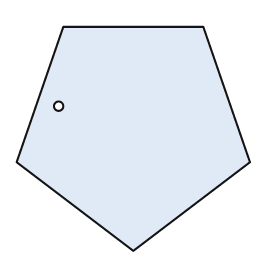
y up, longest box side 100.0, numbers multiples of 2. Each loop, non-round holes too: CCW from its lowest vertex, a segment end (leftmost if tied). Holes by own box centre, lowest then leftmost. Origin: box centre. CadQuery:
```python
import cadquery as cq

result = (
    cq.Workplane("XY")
    .moveTo(0.0, -48.0)
    .lineTo(50.0, -10.0)
    .lineTo(30.0, 48.0)
    .lineTo(-30.0, 48.0)
    .lineTo(-50.0, -10.0)
    .close()
    .moveTo(-32.0, 14.0)
    .circle(2.0)
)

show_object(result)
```